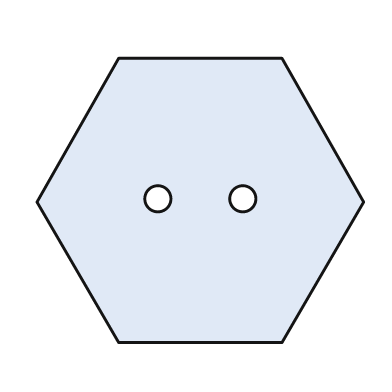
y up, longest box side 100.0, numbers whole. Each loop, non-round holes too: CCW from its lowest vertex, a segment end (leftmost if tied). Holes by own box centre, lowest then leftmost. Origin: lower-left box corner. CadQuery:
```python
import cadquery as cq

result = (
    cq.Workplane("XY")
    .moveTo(25.0, 0.0)
    .lineTo(75.0, 0.0)
    .lineTo(100.0, 43.0)
    .lineTo(75.0, 87.0)
    .lineTo(25.0, 87.0)
    .lineTo(0.0, 43.0)
    .close()
    .moveTo(37.0, 44.0)
    .circle(4.0)
    .moveTo(63.0, 44.0)
    .circle(4.0)
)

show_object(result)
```